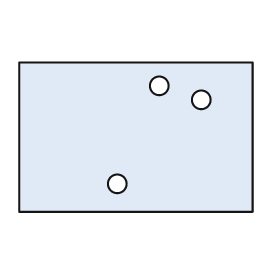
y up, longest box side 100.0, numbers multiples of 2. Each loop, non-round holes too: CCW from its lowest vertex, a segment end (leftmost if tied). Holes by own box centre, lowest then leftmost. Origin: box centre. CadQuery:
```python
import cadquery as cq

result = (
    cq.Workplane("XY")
    .moveTo(-50.0, -32.0)
    .lineTo(50.0, -32.0)
    .lineTo(50.0, 32.0)
    .lineTo(-50.0, 32.0)
    .close()
    .moveTo(-8.0, -20.0)
    .circle(4.0)
    .moveTo(28.0, 16.0)
    .circle(4.0)
    .moveTo(10.0, 22.0)
    .circle(4.0)
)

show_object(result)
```